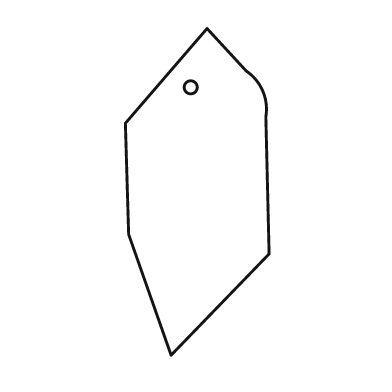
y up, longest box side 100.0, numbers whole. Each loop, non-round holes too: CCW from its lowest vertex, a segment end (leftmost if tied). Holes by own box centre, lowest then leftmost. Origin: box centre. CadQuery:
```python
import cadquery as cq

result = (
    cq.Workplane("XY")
    .moveTo(-8.0, -50.0)
    .lineTo(22.0, -19.0)
    .lineTo(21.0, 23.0)
    .threePointArc((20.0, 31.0), (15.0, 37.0))
    .lineTo(3.0, 50.0)
    .lineTo(-22.0, 21.0)
    .lineTo(-21.0, -13.0)
    .close()
    .moveTo(-2.0, 32.0)
    .circle(2.0)
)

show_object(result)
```